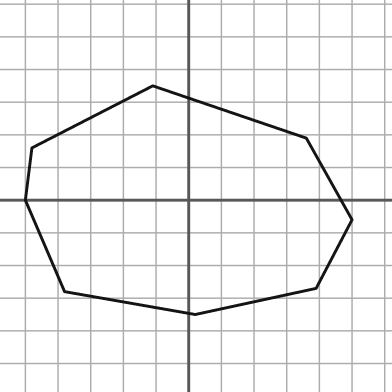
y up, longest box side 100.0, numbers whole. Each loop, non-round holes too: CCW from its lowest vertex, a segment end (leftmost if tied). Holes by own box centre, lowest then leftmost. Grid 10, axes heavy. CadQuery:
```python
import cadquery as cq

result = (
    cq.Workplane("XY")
    .moveTo(2.0, -35.0)
    .lineTo(39.0, -27.0)
    .lineTo(50.0, -6.0)
    .lineTo(36.0, 19.0)
    .lineTo(-11.0, 35.0)
    .lineTo(-48.0, 16.0)
    .lineTo(-50.0, 0.0)
    .lineTo(-38.0, -28.0)
    .close()
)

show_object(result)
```